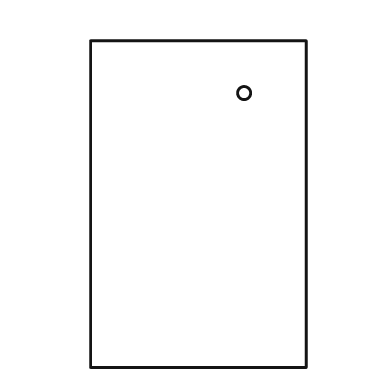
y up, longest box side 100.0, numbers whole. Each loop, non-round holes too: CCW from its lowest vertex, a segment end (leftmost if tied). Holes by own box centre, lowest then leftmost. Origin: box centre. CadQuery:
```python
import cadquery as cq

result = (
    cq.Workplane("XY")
    .moveTo(-33.0, -50.0)
    .lineTo(33.0, -50.0)
    .lineTo(33.0, 50.0)
    .lineTo(-33.0, 50.0)
    .close()
    .moveTo(14.0, 34.0)
    .circle(2.0)
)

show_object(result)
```